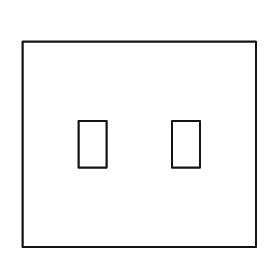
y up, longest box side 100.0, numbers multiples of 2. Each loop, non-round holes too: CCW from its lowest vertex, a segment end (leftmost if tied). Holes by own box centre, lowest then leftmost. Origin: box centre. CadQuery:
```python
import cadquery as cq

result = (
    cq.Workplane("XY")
    .moveTo(-50.0, -44.0)
    .lineTo(50.0, -44.0)
    .lineTo(50.0, 44.0)
    .lineTo(-50.0, 44.0)
    .close()
    .moveTo(-26.0, -10.0)
    .lineTo(-14.0, -10.0)
    .lineTo(-14.0, 10.0)
    .lineTo(-26.0, 10.0)
    .close()
    .moveTo(14.0, -10.0)
    .lineTo(26.0, -10.0)
    .lineTo(26.0, 10.0)
    .lineTo(14.0, 10.0)
    .close()
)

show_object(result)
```